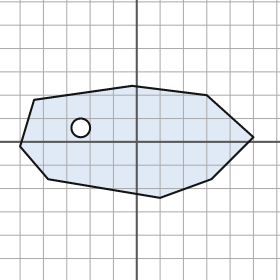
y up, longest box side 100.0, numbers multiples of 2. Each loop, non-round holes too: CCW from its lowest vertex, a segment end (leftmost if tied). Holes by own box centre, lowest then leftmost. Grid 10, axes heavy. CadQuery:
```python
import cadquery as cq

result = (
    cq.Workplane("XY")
    .moveTo(10.0, -24.0)
    .lineTo(32.0, -16.0)
    .lineTo(50.0, 2.0)
    .lineTo(30.0, 20.0)
    .lineTo(-2.0, 24.0)
    .lineTo(-44.0, 18.0)
    .lineTo(-50.0, -2.0)
    .lineTo(-38.0, -16.0)
    .close()
    .moveTo(-24.0, 6.0)
    .circle(4.0)
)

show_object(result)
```